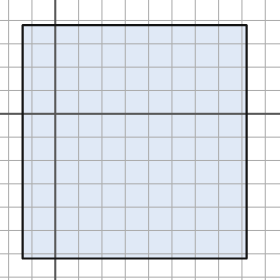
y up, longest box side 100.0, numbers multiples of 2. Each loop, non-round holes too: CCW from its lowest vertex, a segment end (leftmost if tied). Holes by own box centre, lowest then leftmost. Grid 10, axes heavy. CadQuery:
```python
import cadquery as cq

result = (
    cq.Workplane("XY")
    .moveTo(-14.0, -62.0)
    .lineTo(82.0, -62.0)
    .lineTo(82.0, 38.0)
    .lineTo(-14.0, 38.0)
    .close()
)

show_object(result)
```